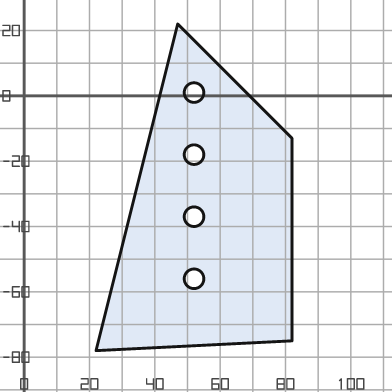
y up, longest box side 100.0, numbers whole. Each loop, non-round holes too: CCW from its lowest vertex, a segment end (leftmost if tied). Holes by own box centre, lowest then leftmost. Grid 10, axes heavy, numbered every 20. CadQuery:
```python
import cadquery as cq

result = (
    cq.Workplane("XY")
    .moveTo(22.0, -78.0)
    .lineTo(82.0, -75.0)
    .lineTo(82.0, -13.0)
    .lineTo(47.0, 22.0)
    .close()
    .moveTo(52.0, -56.0)
    .circle(3.0)
    .moveTo(52.0, -37.0)
    .circle(3.0)
    .moveTo(52.0, -18.0)
    .circle(3.0)
    .moveTo(52.0, 1.0)
    .circle(3.0)
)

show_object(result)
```